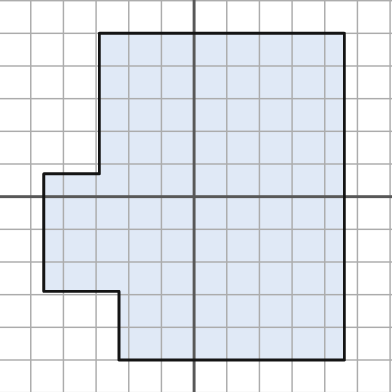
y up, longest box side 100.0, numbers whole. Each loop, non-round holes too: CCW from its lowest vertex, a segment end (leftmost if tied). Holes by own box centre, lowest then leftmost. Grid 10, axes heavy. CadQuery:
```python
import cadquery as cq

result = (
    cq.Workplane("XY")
    .moveTo(-23.0, -50.0)
    .lineTo(46.0, -50.0)
    .lineTo(46.0, 50.0)
    .lineTo(-29.0, 50.0)
    .lineTo(-29.0, 7.0)
    .lineTo(-46.0, 7.0)
    .lineTo(-46.0, -29.0)
    .lineTo(-23.0, -29.0)
    .close()
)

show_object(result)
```